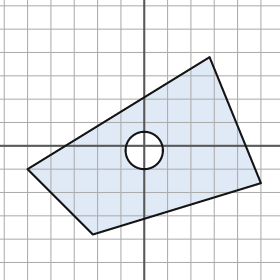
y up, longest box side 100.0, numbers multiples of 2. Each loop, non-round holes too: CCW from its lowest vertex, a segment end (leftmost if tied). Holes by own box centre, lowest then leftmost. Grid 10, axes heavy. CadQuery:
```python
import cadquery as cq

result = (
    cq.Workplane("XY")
    .moveTo(-22.0, -38.0)
    .lineTo(50.0, -16.0)
    .lineTo(28.0, 38.0)
    .lineTo(-50.0, -10.0)
    .close()
    .moveTo(0.0, -2.0)
    .circle(8.0)
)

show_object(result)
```